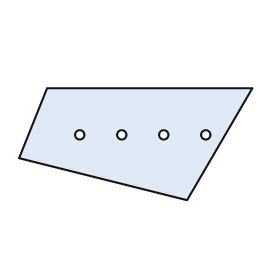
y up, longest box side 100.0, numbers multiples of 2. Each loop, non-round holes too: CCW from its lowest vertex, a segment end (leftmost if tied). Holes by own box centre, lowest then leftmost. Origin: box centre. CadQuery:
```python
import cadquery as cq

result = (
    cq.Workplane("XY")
    .moveTo(22.0, -24.0)
    .lineTo(50.0, 24.0)
    .lineTo(-38.0, 24.0)
    .lineTo(-50.0, -6.0)
    .close()
    .moveTo(-24.0, 4.0)
    .circle(2.0)
    .moveTo(-6.0, 4.0)
    .circle(2.0)
    .moveTo(12.0, 4.0)
    .circle(2.0)
    .moveTo(30.0, 4.0)
    .circle(2.0)
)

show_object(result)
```